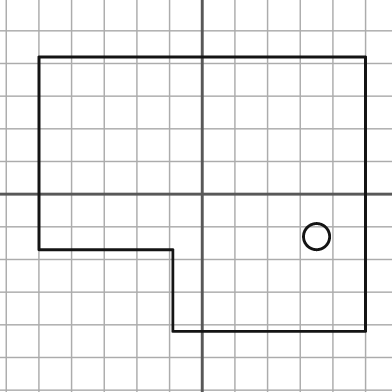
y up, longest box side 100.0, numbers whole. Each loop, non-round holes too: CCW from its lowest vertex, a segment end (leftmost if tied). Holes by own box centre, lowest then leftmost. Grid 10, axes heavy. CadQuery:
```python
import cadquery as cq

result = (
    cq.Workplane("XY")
    .moveTo(-9.0, -42.0)
    .lineTo(50.0, -42.0)
    .lineTo(50.0, 42.0)
    .lineTo(-50.0, 42.0)
    .lineTo(-50.0, -17.0)
    .lineTo(-9.0, -17.0)
    .close()
    .moveTo(35.0, -13.0)
    .circle(4.0)
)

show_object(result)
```